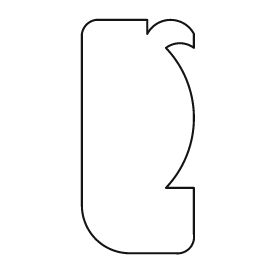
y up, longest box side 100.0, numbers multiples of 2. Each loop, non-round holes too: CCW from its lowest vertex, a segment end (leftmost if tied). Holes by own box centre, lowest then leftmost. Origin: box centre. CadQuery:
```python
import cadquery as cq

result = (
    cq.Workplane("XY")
    .moveTo(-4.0, -50.0)
    .lineTo(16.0, -50.0)
    .threePointArc((22.0, -48.0), (24.0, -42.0))
    .lineTo(24.0, -22.0)
    .lineTo(12.0, -22.0)
    .threePointArc((24.0, 8.0), (12.0, 38.0))
    .threePointArc((18.0, 40.0), (24.0, 38.0))
    .lineTo(24.0, 44.0)
    .threePointArc((14.0, 50.0), (4.0, 44.0))
    .lineTo(4.0, 50.0)
    .lineTo(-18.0, 50.0)
    .threePointArc((-22.0, 48.0), (-24.0, 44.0))
    .lineTo(-24.0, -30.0)
    .threePointArc((-18.0, -44.0), (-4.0, -50.0))
    .close()
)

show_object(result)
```